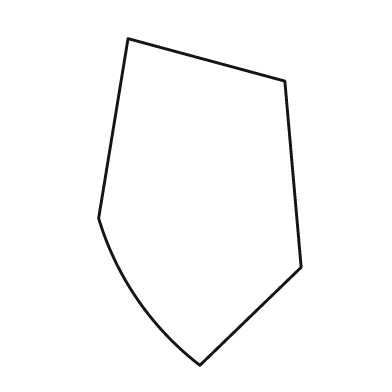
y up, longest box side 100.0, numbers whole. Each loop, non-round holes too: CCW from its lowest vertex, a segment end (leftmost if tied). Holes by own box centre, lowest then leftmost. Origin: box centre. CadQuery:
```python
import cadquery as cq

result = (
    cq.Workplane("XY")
    .moveTo(0.0, -50.0)
    .lineTo(31.0, -20.0)
    .lineTo(26.0, 37.0)
    .lineTo(-22.0, 50.0)
    .lineTo(-31.0, -5.0)
    .threePointArc((-19.0, -30.0), (0.0, -50.0))
    .close()
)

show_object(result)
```